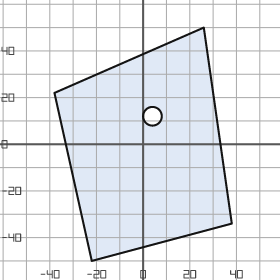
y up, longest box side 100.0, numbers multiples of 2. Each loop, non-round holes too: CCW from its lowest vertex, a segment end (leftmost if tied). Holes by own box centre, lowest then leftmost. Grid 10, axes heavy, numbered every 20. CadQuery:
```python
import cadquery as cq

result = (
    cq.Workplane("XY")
    .moveTo(-22.0, -50.0)
    .lineTo(38.0, -34.0)
    .lineTo(26.0, 50.0)
    .lineTo(-38.0, 22.0)
    .close()
    .moveTo(4.0, 12.0)
    .circle(4.0)
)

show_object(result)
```